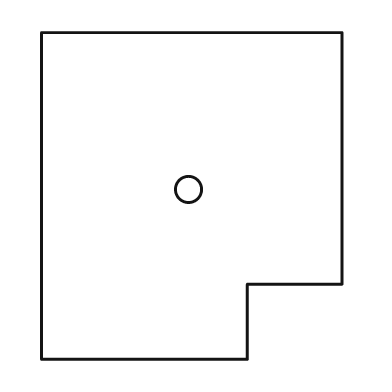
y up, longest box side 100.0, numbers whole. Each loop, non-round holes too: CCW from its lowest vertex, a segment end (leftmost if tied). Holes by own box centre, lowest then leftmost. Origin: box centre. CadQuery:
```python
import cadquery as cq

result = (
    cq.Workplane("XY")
    .moveTo(-46.0, -50.0)
    .lineTo(17.0, -50.0)
    .lineTo(17.0, -27.0)
    .lineTo(46.0, -27.0)
    .lineTo(46.0, 50.0)
    .lineTo(-46.0, 50.0)
    .close()
    .moveTo(-1.0, 2.0)
    .circle(4.0)
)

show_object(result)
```